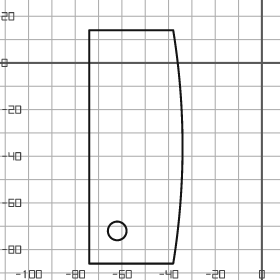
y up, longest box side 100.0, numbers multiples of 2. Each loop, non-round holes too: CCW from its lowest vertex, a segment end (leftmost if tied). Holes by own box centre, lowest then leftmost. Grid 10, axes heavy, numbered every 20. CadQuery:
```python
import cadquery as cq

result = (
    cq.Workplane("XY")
    .moveTo(-74.0, -86.0)
    .lineTo(-38.0, -86.0)
    .threePointArc((-34.0, -36.0), (-38.0, 14.0))
    .lineTo(-74.0, 14.0)
    .close()
    .moveTo(-62.0, -72.0)
    .circle(4.0)
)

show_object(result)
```